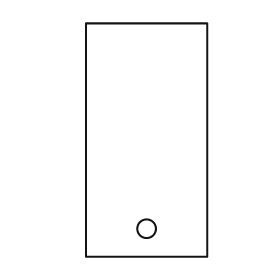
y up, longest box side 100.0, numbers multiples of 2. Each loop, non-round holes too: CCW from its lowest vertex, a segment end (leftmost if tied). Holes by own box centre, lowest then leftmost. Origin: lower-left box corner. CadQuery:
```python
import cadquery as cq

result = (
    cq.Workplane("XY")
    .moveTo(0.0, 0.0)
    .lineTo(52.0, 0.0)
    .lineTo(52.0, 100.0)
    .lineTo(0.0, 100.0)
    .close()
    .moveTo(26.0, 12.0)
    .circle(4.0)
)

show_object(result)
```